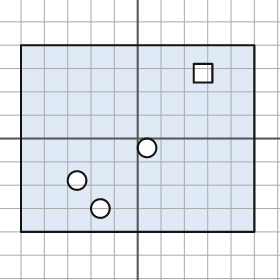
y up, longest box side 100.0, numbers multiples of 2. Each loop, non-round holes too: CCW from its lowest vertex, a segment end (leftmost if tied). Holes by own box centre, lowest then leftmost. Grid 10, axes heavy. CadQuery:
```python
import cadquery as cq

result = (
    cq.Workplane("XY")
    .moveTo(-50.0, -40.0)
    .lineTo(50.0, -40.0)
    .lineTo(50.0, 40.0)
    .lineTo(-50.0, 40.0)
    .close()
    .moveTo(-16.0, -30.0)
    .circle(4.0)
    .moveTo(-26.0, -18.0)
    .circle(4.0)
    .moveTo(4.0, -4.0)
    .circle(4.0)
    .moveTo(24.0, 24.0)
    .lineTo(32.0, 24.0)
    .lineTo(32.0, 32.0)
    .lineTo(24.0, 32.0)
    .close()
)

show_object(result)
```